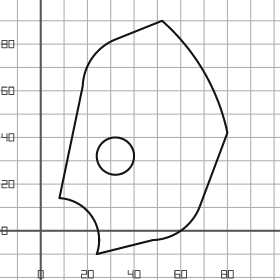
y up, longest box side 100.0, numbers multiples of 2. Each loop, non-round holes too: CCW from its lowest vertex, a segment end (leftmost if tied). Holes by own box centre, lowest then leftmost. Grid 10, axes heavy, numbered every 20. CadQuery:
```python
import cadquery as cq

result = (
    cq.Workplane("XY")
    .moveTo(24.0, -10.0)
    .lineTo(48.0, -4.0)
    .threePointArc((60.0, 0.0), (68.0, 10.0))
    .lineTo(80.0, 42.0)
    .threePointArc((70.0, 68.0), (52.0, 90.0))
    .lineTo(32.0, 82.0)
    .threePointArc((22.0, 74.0), (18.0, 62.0))
    .lineTo(8.0, 14.0)
    .threePointArc((22.0, 6.0), (24.0, -10.0))
    .close()
    .moveTo(32.0, 32.0)
    .circle(8.0)
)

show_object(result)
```